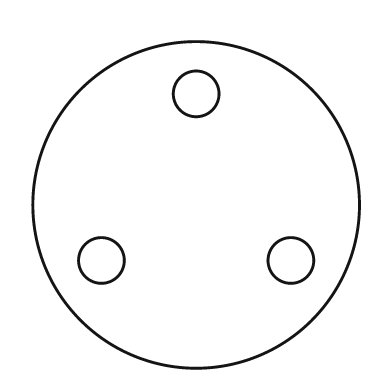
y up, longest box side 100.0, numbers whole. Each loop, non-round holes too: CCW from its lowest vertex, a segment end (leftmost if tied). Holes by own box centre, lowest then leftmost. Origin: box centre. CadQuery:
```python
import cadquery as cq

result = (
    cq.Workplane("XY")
    .moveTo(0.0, 0.0)
    .circle(50.0)
    .moveTo(-29.0, -17.0)
    .circle(7.0)
    .moveTo(29.0, -17.0)
    .circle(7.0)
    .moveTo(0.0, 34.0)
    .circle(7.0)
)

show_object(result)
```